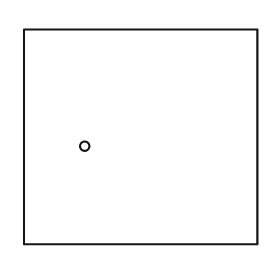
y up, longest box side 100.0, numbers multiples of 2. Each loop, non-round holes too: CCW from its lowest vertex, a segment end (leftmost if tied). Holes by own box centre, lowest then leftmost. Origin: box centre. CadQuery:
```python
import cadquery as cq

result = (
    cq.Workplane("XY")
    .moveTo(-50.0, -46.0)
    .lineTo(50.0, -46.0)
    .lineTo(50.0, 46.0)
    .lineTo(-50.0, 46.0)
    .close()
    .moveTo(-24.0, -4.0)
    .circle(2.0)
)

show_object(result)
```